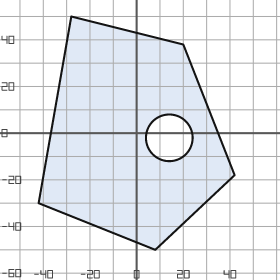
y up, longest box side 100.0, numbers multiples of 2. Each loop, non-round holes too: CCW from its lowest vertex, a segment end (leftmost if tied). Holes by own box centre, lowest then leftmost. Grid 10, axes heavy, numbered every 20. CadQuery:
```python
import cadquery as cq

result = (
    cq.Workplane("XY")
    .moveTo(8.0, -50.0)
    .lineTo(42.0, -18.0)
    .lineTo(20.0, 38.0)
    .lineTo(-28.0, 50.0)
    .lineTo(-42.0, -30.0)
    .close()
    .moveTo(14.0, -2.0)
    .circle(10.0)
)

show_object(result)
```